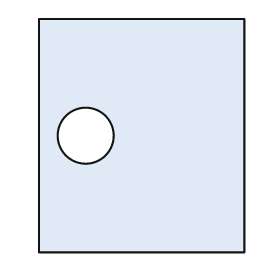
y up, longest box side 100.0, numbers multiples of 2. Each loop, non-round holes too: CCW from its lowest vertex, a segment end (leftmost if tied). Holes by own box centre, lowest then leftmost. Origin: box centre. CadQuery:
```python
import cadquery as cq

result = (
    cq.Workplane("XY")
    .moveTo(-44.0, -50.0)
    .lineTo(44.0, -50.0)
    .lineTo(44.0, 50.0)
    .lineTo(-44.0, 50.0)
    .close()
    .moveTo(-24.0, 0.0)
    .circle(12.0)
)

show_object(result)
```